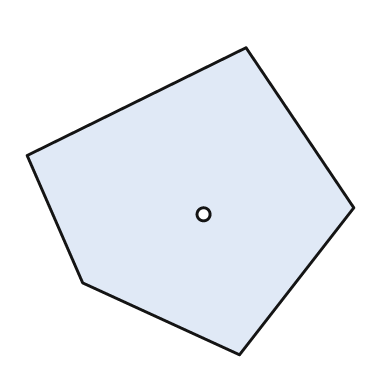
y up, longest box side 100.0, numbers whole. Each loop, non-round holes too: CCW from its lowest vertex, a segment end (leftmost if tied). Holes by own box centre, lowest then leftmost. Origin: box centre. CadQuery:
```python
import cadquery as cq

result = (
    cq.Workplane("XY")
    .moveTo(15.0, -47.0)
    .lineTo(50.0, -2.0)
    .lineTo(17.0, 47.0)
    .lineTo(-50.0, 14.0)
    .lineTo(-33.0, -25.0)
    .close()
    .moveTo(4.0, -4.0)
    .circle(2.0)
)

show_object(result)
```